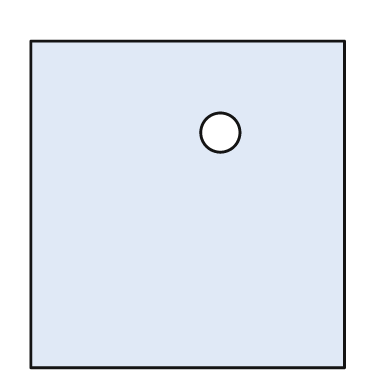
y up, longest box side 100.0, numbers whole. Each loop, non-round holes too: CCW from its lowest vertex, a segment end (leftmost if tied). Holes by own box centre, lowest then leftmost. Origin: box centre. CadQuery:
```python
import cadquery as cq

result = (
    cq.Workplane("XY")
    .moveTo(-48.0, -50.0)
    .lineTo(48.0, -50.0)
    .lineTo(48.0, 50.0)
    .lineTo(-48.0, 50.0)
    .close()
    .moveTo(10.0, 22.0)
    .circle(6.0)
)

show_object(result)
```